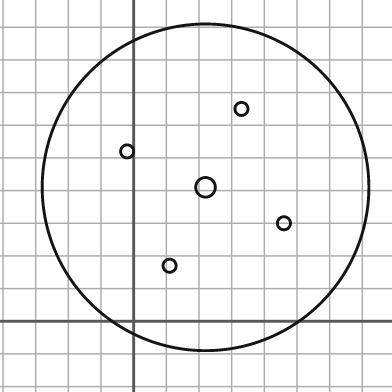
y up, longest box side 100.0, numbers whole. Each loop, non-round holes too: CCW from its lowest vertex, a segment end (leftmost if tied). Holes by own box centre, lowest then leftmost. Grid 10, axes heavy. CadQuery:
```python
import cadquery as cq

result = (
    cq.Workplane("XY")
    .moveTo(22.0, 41.0)
    .circle(50.0)
    .moveTo(11.0, 17.0)
    .circle(2.0)
    .moveTo(46.0, 30.0)
    .circle(2.0)
    .moveTo(22.0, 41.0)
    .circle(3.0)
    .moveTo(-2.0, 52.0)
    .circle(2.0)
    .moveTo(33.0, 65.0)
    .circle(2.0)
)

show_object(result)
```